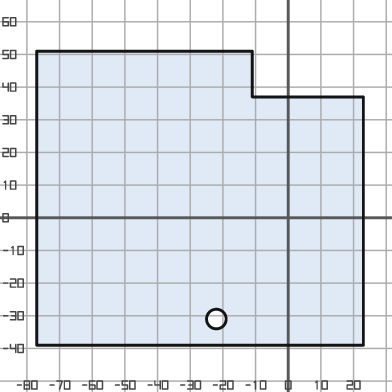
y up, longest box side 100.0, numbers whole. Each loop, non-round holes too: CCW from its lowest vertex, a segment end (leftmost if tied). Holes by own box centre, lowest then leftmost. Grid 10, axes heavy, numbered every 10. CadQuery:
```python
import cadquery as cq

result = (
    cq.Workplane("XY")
    .moveTo(-77.0, -39.0)
    .lineTo(23.0, -39.0)
    .lineTo(23.0, 37.0)
    .lineTo(-11.0, 37.0)
    .lineTo(-11.0, 51.0)
    .lineTo(-77.0, 51.0)
    .close()
    .moveTo(-22.0, -31.0)
    .circle(3.0)
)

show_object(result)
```